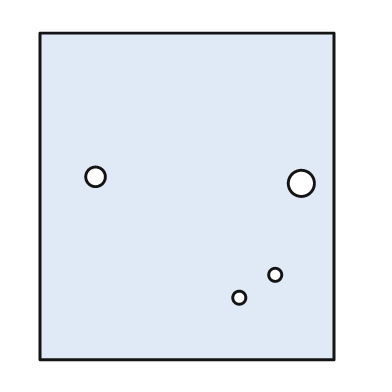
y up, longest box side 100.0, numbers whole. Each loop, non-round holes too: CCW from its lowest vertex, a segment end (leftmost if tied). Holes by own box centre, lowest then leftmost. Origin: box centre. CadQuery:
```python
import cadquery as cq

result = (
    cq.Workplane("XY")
    .moveTo(-45.0, -50.0)
    .lineTo(45.0, -50.0)
    .lineTo(45.0, 50.0)
    .lineTo(-45.0, 50.0)
    .close()
    .moveTo(16.0, -31.0)
    .circle(2.0)
    .moveTo(27.0, -24.0)
    .circle(2.0)
    .moveTo(35.0, 4.0)
    .circle(4.0)
    .moveTo(-28.0, 6.0)
    .circle(3.0)
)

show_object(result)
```